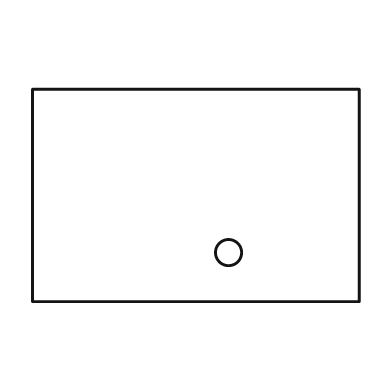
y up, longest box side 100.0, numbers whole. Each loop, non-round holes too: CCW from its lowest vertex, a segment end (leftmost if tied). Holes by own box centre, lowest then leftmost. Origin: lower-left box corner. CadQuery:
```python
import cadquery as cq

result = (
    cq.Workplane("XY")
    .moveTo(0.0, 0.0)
    .lineTo(100.0, 0.0)
    .lineTo(100.0, 65.0)
    .lineTo(0.0, 65.0)
    .close()
    .moveTo(60.0, 15.0)
    .circle(4.0)
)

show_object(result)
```